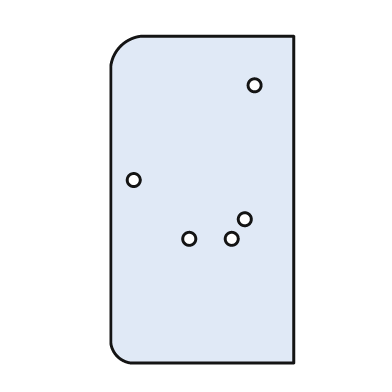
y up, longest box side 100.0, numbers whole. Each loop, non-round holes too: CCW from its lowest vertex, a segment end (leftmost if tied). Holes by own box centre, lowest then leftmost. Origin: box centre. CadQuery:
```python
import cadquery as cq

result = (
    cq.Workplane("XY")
    .moveTo(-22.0, -50.0)
    .lineTo(28.0, -50.0)
    .lineTo(28.0, 50.0)
    .lineTo(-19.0, 50.0)
    .threePointArc((-25.0, 47.0), (-28.0, 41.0))
    .lineTo(-28.0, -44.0)
    .threePointArc((-26.0, -48.0), (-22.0, -50.0))
    .close()
    .moveTo(-4.0, -12.0)
    .circle(2.0)
    .moveTo(9.0, -12.0)
    .circle(2.0)
    .moveTo(13.0, -6.0)
    .circle(2.0)
    .moveTo(-21.0, 6.0)
    .circle(2.0)
    .moveTo(16.0, 35.0)
    .circle(2.0)
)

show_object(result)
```